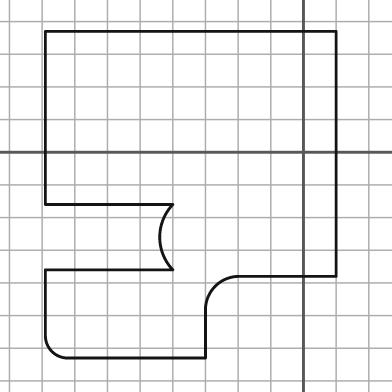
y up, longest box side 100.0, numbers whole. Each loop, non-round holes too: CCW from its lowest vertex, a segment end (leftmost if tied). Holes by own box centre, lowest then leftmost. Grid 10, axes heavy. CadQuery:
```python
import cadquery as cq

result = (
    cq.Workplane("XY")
    .moveTo(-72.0, -63.0)
    .lineTo(-30.0, -63.0)
    .lineTo(-30.0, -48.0)
    .threePointArc((-27.0, -41.0), (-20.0, -38.0))
    .lineTo(10.0, -38.0)
    .lineTo(10.0, 37.0)
    .lineTo(-79.0, 37.0)
    .lineTo(-79.0, -16.0)
    .lineTo(-40.0, -16.0)
    .threePointArc((-44.0, -26.0), (-40.0, -36.0))
    .lineTo(-79.0, -36.0)
    .lineTo(-79.0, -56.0)
    .threePointArc((-77.0, -61.0), (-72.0, -63.0))
    .close()
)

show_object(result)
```